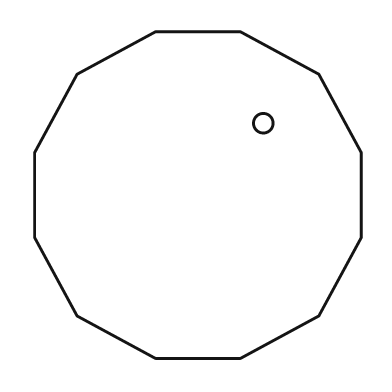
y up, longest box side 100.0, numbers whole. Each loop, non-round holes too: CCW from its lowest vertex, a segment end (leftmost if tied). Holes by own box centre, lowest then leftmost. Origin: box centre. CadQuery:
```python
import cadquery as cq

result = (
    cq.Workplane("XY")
    .moveTo(-13.0, -50.0)
    .lineTo(13.0, -50.0)
    .lineTo(37.0, -37.0)
    .lineTo(50.0, -13.0)
    .lineTo(50.0, 13.0)
    .lineTo(37.0, 37.0)
    .lineTo(13.0, 50.0)
    .lineTo(-13.0, 50.0)
    .lineTo(-37.0, 37.0)
    .lineTo(-50.0, 13.0)
    .lineTo(-50.0, -13.0)
    .lineTo(-37.0, -37.0)
    .close()
    .moveTo(20.0, 22.0)
    .circle(3.0)
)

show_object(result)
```